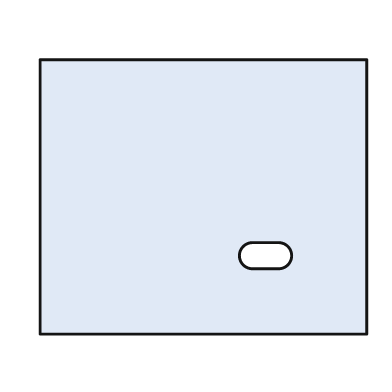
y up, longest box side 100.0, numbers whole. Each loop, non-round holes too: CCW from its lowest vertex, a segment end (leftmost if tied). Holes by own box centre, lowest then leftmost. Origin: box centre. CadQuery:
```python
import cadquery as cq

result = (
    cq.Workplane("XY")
    .moveTo(-50.0, -42.0)
    .lineTo(50.0, -42.0)
    .lineTo(50.0, 42.0)
    .lineTo(-50.0, 42.0)
    .close()
    .moveTo(15.0, -22.0)
    .lineTo(23.0, -22.0)
    .threePointArc((27.0, -18.0), (23.0, -14.0))
    .lineTo(15.0, -14.0)
    .threePointArc((11.0, -18.0), (15.0, -22.0))
    .close()
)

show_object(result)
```